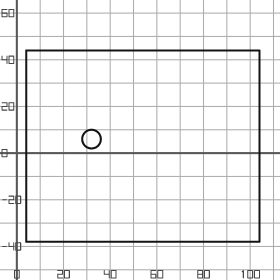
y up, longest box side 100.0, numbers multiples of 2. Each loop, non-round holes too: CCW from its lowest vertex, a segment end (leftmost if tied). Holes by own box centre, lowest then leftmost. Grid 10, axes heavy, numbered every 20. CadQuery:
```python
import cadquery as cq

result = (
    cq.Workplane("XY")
    .moveTo(4.0, -38.0)
    .lineTo(104.0, -38.0)
    .lineTo(104.0, 44.0)
    .lineTo(4.0, 44.0)
    .close()
    .moveTo(32.0, 6.0)
    .circle(4.0)
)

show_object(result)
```